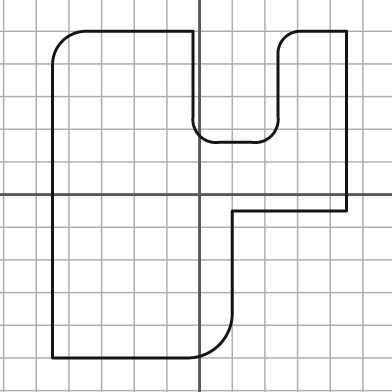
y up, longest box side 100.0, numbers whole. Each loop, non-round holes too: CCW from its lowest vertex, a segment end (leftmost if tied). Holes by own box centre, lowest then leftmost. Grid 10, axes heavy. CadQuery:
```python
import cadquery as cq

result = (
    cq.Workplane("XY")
    .moveTo(-45.0, -50.0)
    .lineTo(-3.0, -50.0)
    .threePointArc((6.0, -46.0), (10.0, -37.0))
    .lineTo(10.0, -5.0)
    .lineTo(45.0, -5.0)
    .lineTo(45.0, 50.0)
    .lineTo(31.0, 50.0)
    .threePointArc((26.0, 48.0), (24.0, 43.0))
    .lineTo(24.0, 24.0)
    .threePointArc((22.0, 18.0), (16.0, 16.0))
    .lineTo(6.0, 16.0)
    .threePointArc((0.0, 18.0), (-2.0, 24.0))
    .lineTo(-2.0, 50.0)
    .lineTo(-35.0, 50.0)
    .threePointArc((-42.0, 47.0), (-45.0, 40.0))
    .close()
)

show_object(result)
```